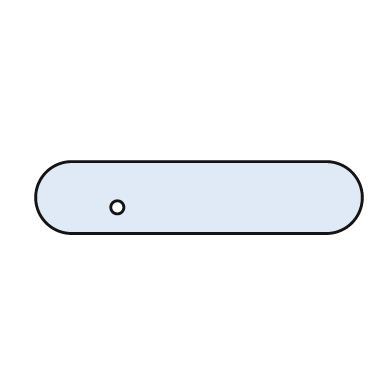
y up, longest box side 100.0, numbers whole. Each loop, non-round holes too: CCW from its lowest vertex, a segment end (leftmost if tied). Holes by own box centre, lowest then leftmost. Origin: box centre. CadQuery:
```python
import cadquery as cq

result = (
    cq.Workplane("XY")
    .moveTo(-39.0, -11.0)
    .lineTo(39.0, -11.0)
    .threePointArc((50.0, 0.0), (39.0, 11.0))
    .lineTo(-39.0, 11.0)
    .threePointArc((-50.0, 0.0), (-39.0, -11.0))
    .close()
    .moveTo(-25.0, -3.0)
    .circle(2.0)
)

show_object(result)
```